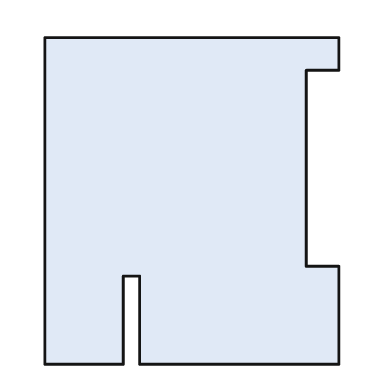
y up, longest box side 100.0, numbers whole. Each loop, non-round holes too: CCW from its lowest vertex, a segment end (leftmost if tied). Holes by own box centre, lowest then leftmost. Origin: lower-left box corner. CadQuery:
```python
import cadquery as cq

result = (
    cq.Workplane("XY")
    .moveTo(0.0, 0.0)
    .lineTo(24.0, 0.0)
    .lineTo(24.0, 27.0)
    .lineTo(29.0, 27.0)
    .lineTo(29.0, 0.0)
    .lineTo(90.0, 0.0)
    .lineTo(90.0, 30.0)
    .lineTo(80.0, 30.0)
    .lineTo(80.0, 90.0)
    .lineTo(90.0, 90.0)
    .lineTo(90.0, 100.0)
    .lineTo(0.0, 100.0)
    .close()
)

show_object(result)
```